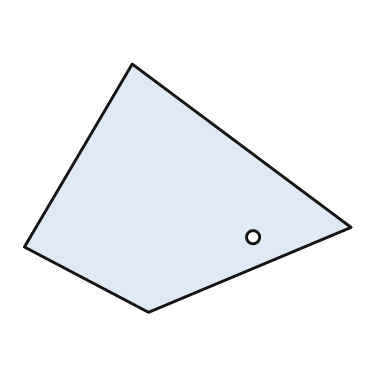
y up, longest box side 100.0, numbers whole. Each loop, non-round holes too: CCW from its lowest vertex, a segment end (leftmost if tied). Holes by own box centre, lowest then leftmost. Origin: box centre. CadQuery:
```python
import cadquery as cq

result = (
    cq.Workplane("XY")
    .moveTo(-12.0, -38.0)
    .lineTo(50.0, -12.0)
    .lineTo(-17.0, 38.0)
    .lineTo(-50.0, -18.0)
    .close()
    .moveTo(20.0, -15.0)
    .circle(2.0)
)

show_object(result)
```